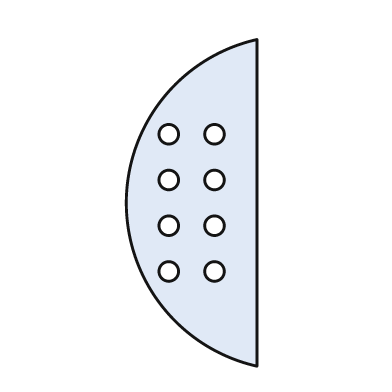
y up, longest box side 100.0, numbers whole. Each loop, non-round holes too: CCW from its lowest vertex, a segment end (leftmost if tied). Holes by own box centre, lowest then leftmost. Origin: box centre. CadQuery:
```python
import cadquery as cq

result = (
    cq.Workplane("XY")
    .moveTo(20.0, -50.0)
    .lineTo(20.0, 50.0)
    .threePointArc((-20.0, 0.0), (20.0, -50.0))
    .close()
    .moveTo(-7.0, -21.0)
    .circle(3.0)
    .moveTo(7.0, -21.0)
    .circle(3.0)
    .moveTo(-7.0, -7.0)
    .circle(3.0)
    .moveTo(7.0, -7.0)
    .circle(3.0)
    .moveTo(-7.0, 7.0)
    .circle(3.0)
    .moveTo(7.0, 7.0)
    .circle(3.0)
    .moveTo(-7.0, 21.0)
    .circle(3.0)
    .moveTo(7.0, 21.0)
    .circle(3.0)
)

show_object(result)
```